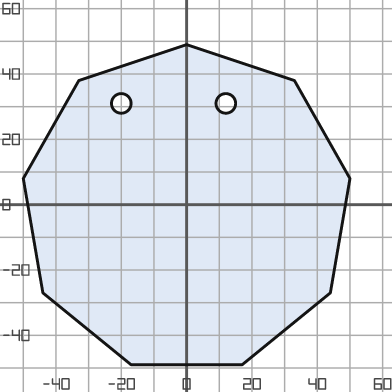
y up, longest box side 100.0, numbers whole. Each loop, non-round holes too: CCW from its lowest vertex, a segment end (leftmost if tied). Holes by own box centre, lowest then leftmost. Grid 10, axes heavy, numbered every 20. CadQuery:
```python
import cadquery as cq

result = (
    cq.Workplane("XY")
    .moveTo(-17.0, -49.0)
    .lineTo(17.0, -49.0)
    .lineTo(44.0, -27.0)
    .lineTo(50.0, 8.0)
    .lineTo(33.0, 38.0)
    .lineTo(0.0, 49.0)
    .lineTo(-33.0, 38.0)
    .lineTo(-50.0, 8.0)
    .lineTo(-44.0, -27.0)
    .close()
    .moveTo(-20.0, 31.0)
    .circle(3.0)
    .moveTo(12.0, 31.0)
    .circle(3.0)
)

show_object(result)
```